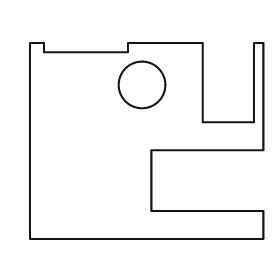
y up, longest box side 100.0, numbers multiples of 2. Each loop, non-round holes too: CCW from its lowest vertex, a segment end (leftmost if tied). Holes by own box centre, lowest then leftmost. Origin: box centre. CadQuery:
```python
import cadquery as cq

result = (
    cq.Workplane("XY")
    .moveTo(-50.0, -42.0)
    .lineTo(50.0, -42.0)
    .lineTo(50.0, -30.0)
    .lineTo(2.0, -30.0)
    .lineTo(2.0, -4.0)
    .lineTo(50.0, -4.0)
    .lineTo(50.0, 42.0)
    .lineTo(46.0, 42.0)
    .lineTo(46.0, 8.0)
    .lineTo(24.0, 8.0)
    .lineTo(24.0, 42.0)
    .lineTo(-8.0, 42.0)
    .lineTo(-8.0, 38.0)
    .lineTo(-44.0, 38.0)
    .lineTo(-44.0, 42.0)
    .lineTo(-50.0, 42.0)
    .close()
    .moveTo(-2.0, 24.0)
    .circle(10.0)
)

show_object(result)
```